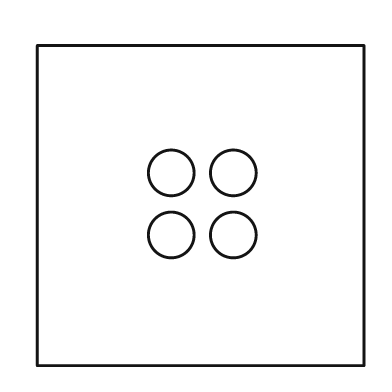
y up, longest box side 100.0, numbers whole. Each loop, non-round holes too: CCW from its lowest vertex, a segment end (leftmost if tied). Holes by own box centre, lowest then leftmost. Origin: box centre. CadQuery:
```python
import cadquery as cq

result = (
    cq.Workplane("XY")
    .moveTo(-50.0, -49.0)
    .lineTo(50.0, -49.0)
    .lineTo(50.0, 49.0)
    .lineTo(-50.0, 49.0)
    .close()
    .moveTo(-9.0, -9.0)
    .circle(7.0)
    .moveTo(10.0, -9.0)
    .circle(7.0)
    .moveTo(-9.0, 10.0)
    .circle(7.0)
    .moveTo(10.0, 10.0)
    .circle(7.0)
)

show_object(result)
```